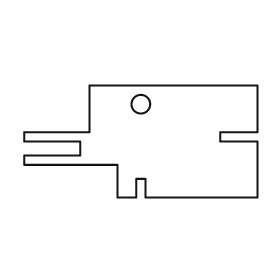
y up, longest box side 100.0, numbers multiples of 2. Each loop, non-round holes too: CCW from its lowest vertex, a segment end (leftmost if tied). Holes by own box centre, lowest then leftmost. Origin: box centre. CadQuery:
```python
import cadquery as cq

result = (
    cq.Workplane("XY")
    .moveTo(-10.0, -24.0)
    .lineTo(-2.0, -24.0)
    .lineTo(-2.0, -16.0)
    .lineTo(2.0, -16.0)
    .lineTo(2.0, -24.0)
    .lineTo(50.0, -24.0)
    .lineTo(50.0, 0.0)
    .lineTo(34.0, 0.0)
    .lineTo(34.0, 4.0)
    .lineTo(50.0, 4.0)
    .lineTo(50.0, 24.0)
    .lineTo(-22.0, 24.0)
    .lineTo(-22.0, 4.0)
    .lineTo(-50.0, 4.0)
    .lineTo(-50.0, 0.0)
    .lineTo(-26.0, 0.0)
    .lineTo(-26.0, -6.0)
    .lineTo(-50.0, -6.0)
    .lineTo(-50.0, -10.0)
    .lineTo(-10.0, -10.0)
    .close()
    .moveTo(0.0, 16.0)
    .circle(4.0)
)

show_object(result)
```